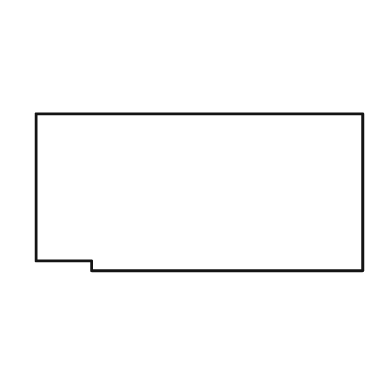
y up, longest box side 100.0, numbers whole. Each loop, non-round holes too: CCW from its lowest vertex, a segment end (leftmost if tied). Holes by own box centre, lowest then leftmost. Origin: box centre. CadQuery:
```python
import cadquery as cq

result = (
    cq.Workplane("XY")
    .moveTo(-33.0, -24.0)
    .lineTo(50.0, -24.0)
    .lineTo(50.0, 24.0)
    .lineTo(-50.0, 24.0)
    .lineTo(-50.0, -21.0)
    .lineTo(-33.0, -21.0)
    .close()
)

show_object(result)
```